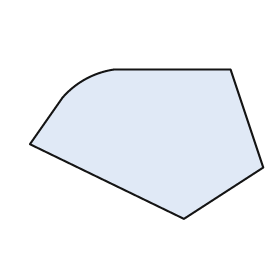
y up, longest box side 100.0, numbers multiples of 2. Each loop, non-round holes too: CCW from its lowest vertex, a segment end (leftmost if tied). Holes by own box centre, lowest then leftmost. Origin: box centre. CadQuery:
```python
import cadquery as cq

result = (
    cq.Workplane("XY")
    .moveTo(16.0, -32.0)
    .lineTo(50.0, -10.0)
    .lineTo(36.0, 32.0)
    .lineTo(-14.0, 32.0)
    .threePointArc((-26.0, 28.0), (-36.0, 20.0))
    .lineTo(-50.0, 0.0)
    .close()
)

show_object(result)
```